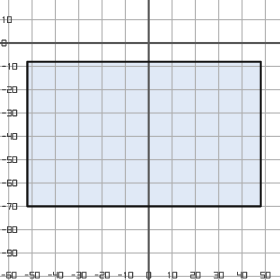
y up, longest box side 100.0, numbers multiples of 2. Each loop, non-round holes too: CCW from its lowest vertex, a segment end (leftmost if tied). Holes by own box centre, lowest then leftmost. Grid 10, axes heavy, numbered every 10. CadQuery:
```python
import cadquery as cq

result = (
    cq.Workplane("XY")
    .moveTo(-52.0, -70.0)
    .lineTo(48.0, -70.0)
    .lineTo(48.0, -8.0)
    .lineTo(-52.0, -8.0)
    .close()
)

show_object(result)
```